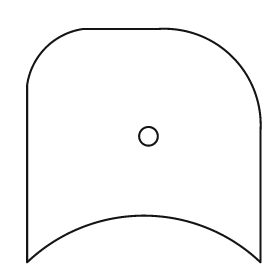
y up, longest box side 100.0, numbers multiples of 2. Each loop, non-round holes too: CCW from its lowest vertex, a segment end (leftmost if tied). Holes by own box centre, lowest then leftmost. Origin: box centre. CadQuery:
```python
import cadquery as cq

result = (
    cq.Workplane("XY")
    .moveTo(-50.0, -50.0)
    .threePointArc((0.0, -30.0), (50.0, -50.0))
    .lineTo(50.0, 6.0)
    .threePointArc((38.0, 38.0), (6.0, 50.0))
    .lineTo(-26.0, 50.0)
    .threePointArc((-42.0, 42.0), (-50.0, 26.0))
    .close()
    .moveTo(2.0, 4.0)
    .circle(4.0)
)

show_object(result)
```